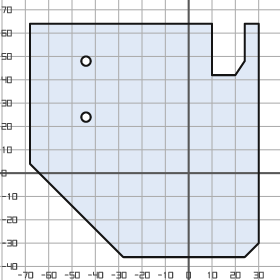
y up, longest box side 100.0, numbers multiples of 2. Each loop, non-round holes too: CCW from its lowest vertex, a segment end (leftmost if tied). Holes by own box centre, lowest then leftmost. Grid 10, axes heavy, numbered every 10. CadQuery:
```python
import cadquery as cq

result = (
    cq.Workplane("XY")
    .moveTo(-28.0, -36.0)
    .lineTo(24.0, -36.0)
    .lineTo(30.0, -30.0)
    .lineTo(30.0, 64.0)
    .lineTo(24.0, 64.0)
    .lineTo(24.0, 48.0)
    .lineTo(20.0, 42.0)
    .lineTo(10.0, 42.0)
    .lineTo(10.0, 64.0)
    .lineTo(-68.0, 64.0)
    .lineTo(-68.0, 4.0)
    .close()
    .moveTo(-44.0, 24.0)
    .circle(2.0)
    .moveTo(-44.0, 48.0)
    .circle(2.0)
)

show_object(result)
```